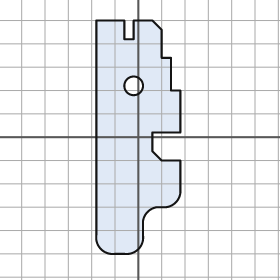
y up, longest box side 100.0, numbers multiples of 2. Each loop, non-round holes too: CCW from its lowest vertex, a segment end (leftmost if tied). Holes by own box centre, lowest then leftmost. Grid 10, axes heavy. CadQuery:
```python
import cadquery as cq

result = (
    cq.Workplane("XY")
    .moveTo(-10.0, -50.0)
    .lineTo(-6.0, -50.0)
    .threePointArc((0.0, -48.0), (2.0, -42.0))
    .lineTo(2.0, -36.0)
    .threePointArc((4.0, -32.0), (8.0, -30.0))
    .lineTo(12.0, -30.0)
    .threePointArc((16.0, -28.0), (18.0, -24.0))
    .lineTo(18.0, -10.0)
    .lineTo(10.0, -10.0)
    .lineTo(6.0, -6.0)
    .lineTo(6.0, 2.0)
    .lineTo(18.0, 2.0)
    .lineTo(18.0, 20.0)
    .lineTo(14.0, 20.0)
    .lineTo(14.0, 34.0)
    .lineTo(10.0, 34.0)
    .lineTo(10.0, 46.0)
    .lineTo(6.0, 50.0)
    .lineTo(-2.0, 50.0)
    .lineTo(-2.0, 42.0)
    .lineTo(-6.0, 42.0)
    .lineTo(-6.0, 50.0)
    .lineTo(-18.0, 50.0)
    .lineTo(-18.0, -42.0)
    .threePointArc((-16.0, -48.0), (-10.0, -50.0))
    .close()
    .moveTo(-2.0, 22.0)
    .circle(4.0)
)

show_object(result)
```